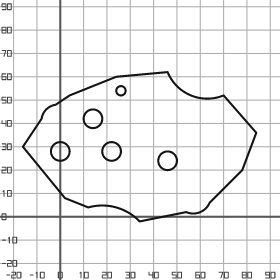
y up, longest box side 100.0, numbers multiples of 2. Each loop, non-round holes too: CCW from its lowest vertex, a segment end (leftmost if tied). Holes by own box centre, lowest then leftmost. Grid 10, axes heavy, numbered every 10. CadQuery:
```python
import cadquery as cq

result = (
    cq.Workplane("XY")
    .moveTo(34.0, -2.0)
    .lineTo(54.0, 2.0)
    .threePointArc((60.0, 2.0), (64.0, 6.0))
    .lineTo(78.0, 20.0)
    .lineTo(84.0, 36.0)
    .lineTo(70.0, 52.0)
    .threePointArc((56.0, 52.0), (46.0, 62.0))
    .lineTo(24.0, 60.0)
    .lineTo(4.0, 52.0)
    .lineTo(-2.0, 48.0)
    .threePointArc((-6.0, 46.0), (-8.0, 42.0))
    .lineTo(-16.0, 30.0)
    .lineTo(2.0, 8.0)
    .lineTo(12.0, 4.0)
    .threePointArc((24.0, 4.0), (34.0, -2.0))
    .close()
    .moveTo(46.0, 24.0)
    .circle(4.0)
    .moveTo(0.0, 28.0)
    .circle(4.0)
    .moveTo(22.0, 28.0)
    .circle(4.0)
    .moveTo(14.0, 42.0)
    .circle(4.0)
    .moveTo(26.0, 54.0)
    .circle(2.0)
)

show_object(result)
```